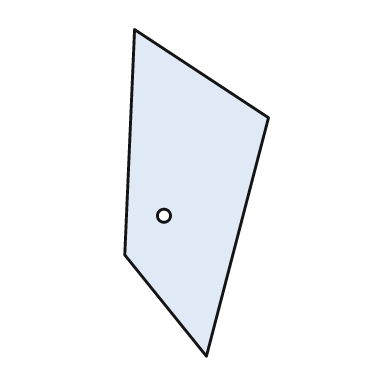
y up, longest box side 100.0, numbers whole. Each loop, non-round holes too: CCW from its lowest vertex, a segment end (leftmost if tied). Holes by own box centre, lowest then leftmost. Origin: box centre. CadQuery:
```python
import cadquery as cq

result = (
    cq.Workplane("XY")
    .moveTo(3.0, -50.0)
    .lineTo(22.0, 23.0)
    .lineTo(-19.0, 50.0)
    .lineTo(-22.0, -19.0)
    .close()
    .moveTo(-10.0, -7.0)
    .circle(2.0)
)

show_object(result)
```